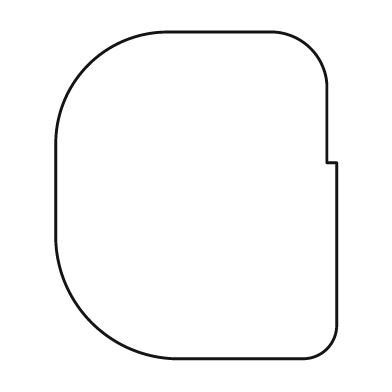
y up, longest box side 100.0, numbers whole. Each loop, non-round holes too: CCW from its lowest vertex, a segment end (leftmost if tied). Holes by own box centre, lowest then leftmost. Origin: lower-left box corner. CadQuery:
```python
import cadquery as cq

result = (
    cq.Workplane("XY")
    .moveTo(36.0, 0.0)
    .lineTo(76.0, 0.0)
    .threePointArc((83.0, 3.0), (86.0, 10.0))
    .lineTo(86.0, 60.0)
    .lineTo(83.0, 60.0)
    .lineTo(83.0, 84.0)
    .threePointArc((78.0, 95.0), (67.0, 100.0))
    .lineTo(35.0, 100.0)
    .threePointArc((10.0, 90.0), (0.0, 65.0))
    .lineTo(0.0, 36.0)
    .threePointArc((11.0, 11.0), (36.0, 0.0))
    .close()
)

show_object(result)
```